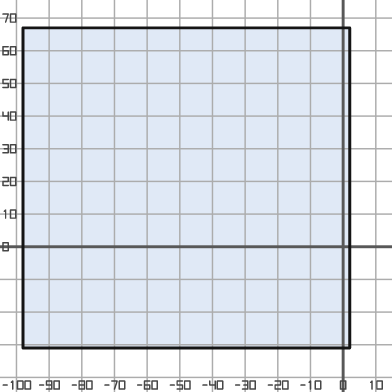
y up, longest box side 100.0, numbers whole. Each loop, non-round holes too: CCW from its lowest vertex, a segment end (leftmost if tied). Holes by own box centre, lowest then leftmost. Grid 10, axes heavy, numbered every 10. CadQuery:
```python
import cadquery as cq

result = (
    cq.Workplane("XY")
    .moveTo(-98.0, -31.0)
    .lineTo(2.0, -31.0)
    .lineTo(2.0, 67.0)
    .lineTo(-98.0, 67.0)
    .close()
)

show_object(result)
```